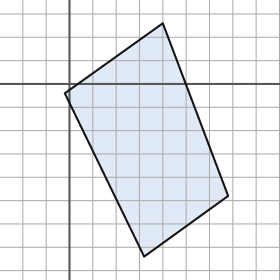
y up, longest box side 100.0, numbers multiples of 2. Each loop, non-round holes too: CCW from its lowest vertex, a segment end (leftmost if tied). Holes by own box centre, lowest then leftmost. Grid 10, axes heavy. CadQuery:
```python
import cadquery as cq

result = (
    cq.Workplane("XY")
    .moveTo(32.0, -74.0)
    .lineTo(68.0, -48.0)
    .lineTo(40.0, 26.0)
    .lineTo(-2.0, -4.0)
    .close()
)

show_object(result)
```